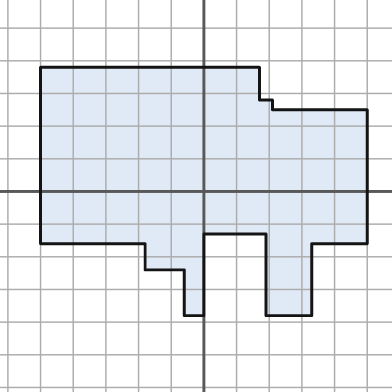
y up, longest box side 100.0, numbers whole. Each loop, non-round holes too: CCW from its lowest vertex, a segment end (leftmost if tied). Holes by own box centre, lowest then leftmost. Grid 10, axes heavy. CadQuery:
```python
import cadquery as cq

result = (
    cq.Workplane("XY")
    .moveTo(-6.0, -38.0)
    .lineTo(0.0, -38.0)
    .lineTo(0.0, -13.0)
    .lineTo(19.0, -13.0)
    .lineTo(19.0, -38.0)
    .lineTo(33.0, -38.0)
    .lineTo(33.0, -16.0)
    .lineTo(50.0, -16.0)
    .lineTo(50.0, 25.0)
    .lineTo(21.0, 25.0)
    .lineTo(21.0, 28.0)
    .lineTo(17.0, 28.0)
    .lineTo(17.0, 38.0)
    .lineTo(-50.0, 38.0)
    .lineTo(-50.0, -16.0)
    .lineTo(-18.0, -16.0)
    .lineTo(-18.0, -24.0)
    .lineTo(-6.0, -24.0)
    .close()
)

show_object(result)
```